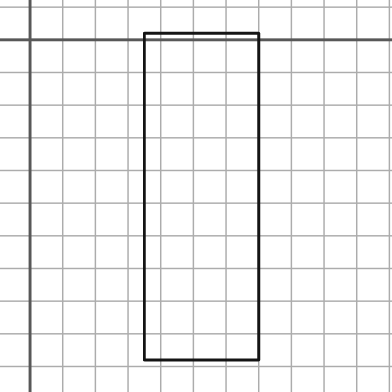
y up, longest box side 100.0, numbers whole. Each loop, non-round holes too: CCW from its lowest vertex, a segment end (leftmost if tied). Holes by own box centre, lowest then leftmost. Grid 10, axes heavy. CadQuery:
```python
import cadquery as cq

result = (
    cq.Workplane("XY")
    .moveTo(35.0, -98.0)
    .lineTo(70.0, -98.0)
    .lineTo(70.0, 2.0)
    .lineTo(35.0, 2.0)
    .close()
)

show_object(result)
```